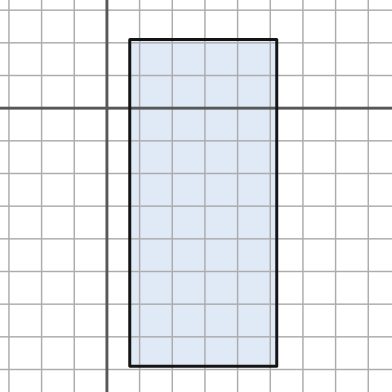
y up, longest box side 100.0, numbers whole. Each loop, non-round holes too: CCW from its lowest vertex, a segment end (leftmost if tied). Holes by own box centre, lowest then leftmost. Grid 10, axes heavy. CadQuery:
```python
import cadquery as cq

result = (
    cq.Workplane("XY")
    .moveTo(7.0, -79.0)
    .lineTo(52.0, -79.0)
    .lineTo(52.0, 21.0)
    .lineTo(7.0, 21.0)
    .close()
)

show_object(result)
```